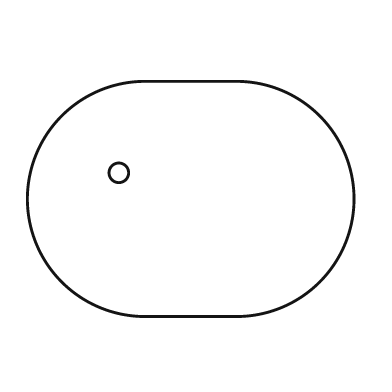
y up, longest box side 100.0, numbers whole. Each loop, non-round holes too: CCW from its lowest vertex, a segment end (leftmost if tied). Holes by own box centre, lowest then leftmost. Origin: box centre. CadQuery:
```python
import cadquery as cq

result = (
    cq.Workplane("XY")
    .moveTo(-14.0, -36.0)
    .lineTo(14.0, -36.0)
    .threePointArc((50.0, 0.0), (14.0, 36.0))
    .lineTo(-14.0, 36.0)
    .threePointArc((-50.0, 0.0), (-14.0, -36.0))
    .close()
    .moveTo(-22.0, 8.0)
    .circle(3.0)
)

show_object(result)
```